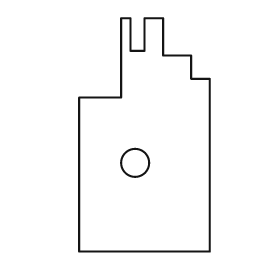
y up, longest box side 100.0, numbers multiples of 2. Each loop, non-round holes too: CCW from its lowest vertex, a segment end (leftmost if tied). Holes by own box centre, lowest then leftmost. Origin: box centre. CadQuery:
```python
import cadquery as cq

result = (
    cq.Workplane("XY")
    .moveTo(-28.0, -50.0)
    .lineTo(28.0, -50.0)
    .lineTo(28.0, 24.0)
    .lineTo(20.0, 24.0)
    .lineTo(20.0, 34.0)
    .lineTo(8.0, 34.0)
    .lineTo(8.0, 50.0)
    .lineTo(0.0, 50.0)
    .lineTo(0.0, 36.0)
    .lineTo(-6.0, 36.0)
    .lineTo(-6.0, 50.0)
    .lineTo(-10.0, 50.0)
    .lineTo(-10.0, 16.0)
    .lineTo(-28.0, 16.0)
    .close()
    .moveTo(-4.0, -12.0)
    .circle(6.0)
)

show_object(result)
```